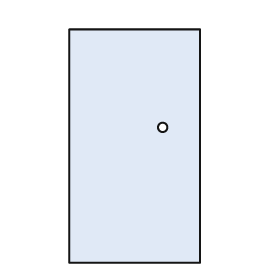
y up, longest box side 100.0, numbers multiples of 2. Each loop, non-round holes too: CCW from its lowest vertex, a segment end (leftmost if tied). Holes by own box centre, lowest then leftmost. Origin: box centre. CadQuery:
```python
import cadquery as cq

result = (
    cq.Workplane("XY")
    .moveTo(-28.0, -50.0)
    .lineTo(28.0, -50.0)
    .lineTo(28.0, 50.0)
    .lineTo(-28.0, 50.0)
    .close()
    .moveTo(12.0, 8.0)
    .circle(2.0)
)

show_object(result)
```